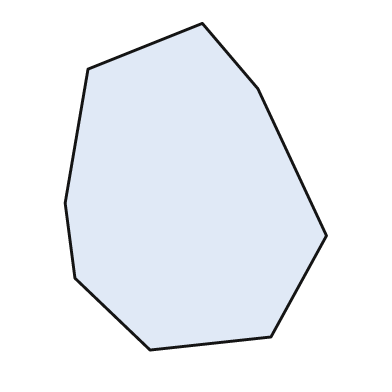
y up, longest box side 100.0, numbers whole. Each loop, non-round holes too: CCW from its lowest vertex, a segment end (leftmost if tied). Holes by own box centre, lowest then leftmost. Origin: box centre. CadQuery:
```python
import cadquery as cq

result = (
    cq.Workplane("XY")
    .moveTo(-14.0, -50.0)
    .lineTo(23.0, -46.0)
    .lineTo(40.0, -15.0)
    .lineTo(19.0, 30.0)
    .lineTo(2.0, 50.0)
    .lineTo(-33.0, 36.0)
    .lineTo(-40.0, -5.0)
    .lineTo(-37.0, -28.0)
    .close()
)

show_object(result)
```